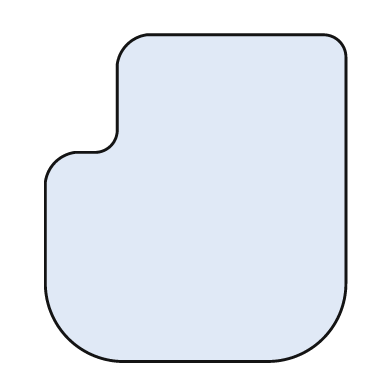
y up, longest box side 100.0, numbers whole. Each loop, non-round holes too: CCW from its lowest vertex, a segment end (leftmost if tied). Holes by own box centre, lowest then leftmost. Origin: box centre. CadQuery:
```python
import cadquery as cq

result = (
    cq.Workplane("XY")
    .moveTo(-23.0, -50.0)
    .lineTo(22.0, -50.0)
    .threePointArc((39.0, -43.0), (46.0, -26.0))
    .lineTo(46.0, 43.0)
    .threePointArc((44.0, 48.0), (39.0, 50.0))
    .lineTo(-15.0, 50.0)
    .threePointArc((-21.0, 47.0), (-24.0, 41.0))
    .lineTo(-24.0, 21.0)
    .threePointArc((-26.0, 16.0), (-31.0, 14.0))
    .lineTo(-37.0, 14.0)
    .threePointArc((-43.0, 11.0), (-46.0, 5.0))
    .lineTo(-46.0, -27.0)
    .threePointArc((-39.0, -43.0), (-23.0, -50.0))
    .close()
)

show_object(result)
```